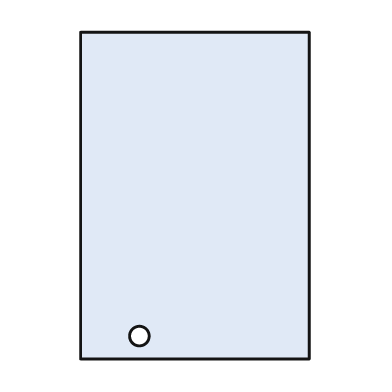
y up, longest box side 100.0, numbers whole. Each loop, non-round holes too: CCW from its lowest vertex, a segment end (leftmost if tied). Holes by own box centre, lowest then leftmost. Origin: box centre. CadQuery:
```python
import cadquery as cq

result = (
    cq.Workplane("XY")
    .moveTo(-35.0, -50.0)
    .lineTo(35.0, -50.0)
    .lineTo(35.0, 50.0)
    .lineTo(-35.0, 50.0)
    .close()
    .moveTo(-17.0, -43.0)
    .circle(3.0)
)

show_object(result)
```